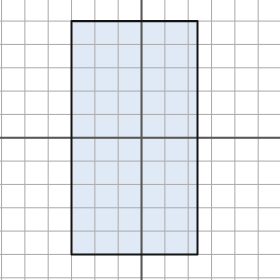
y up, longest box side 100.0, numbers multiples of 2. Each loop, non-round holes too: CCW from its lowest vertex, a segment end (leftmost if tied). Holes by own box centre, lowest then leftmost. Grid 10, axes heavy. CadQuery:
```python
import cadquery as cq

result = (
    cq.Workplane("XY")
    .moveTo(-30.0, -50.0)
    .lineTo(24.0, -50.0)
    .lineTo(24.0, 50.0)
    .lineTo(-30.0, 50.0)
    .close()
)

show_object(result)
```